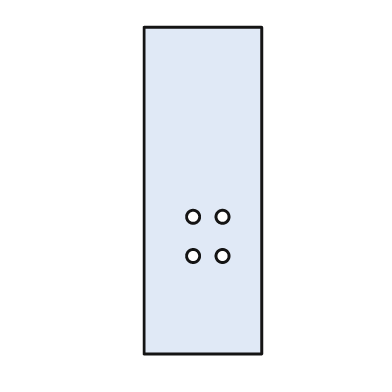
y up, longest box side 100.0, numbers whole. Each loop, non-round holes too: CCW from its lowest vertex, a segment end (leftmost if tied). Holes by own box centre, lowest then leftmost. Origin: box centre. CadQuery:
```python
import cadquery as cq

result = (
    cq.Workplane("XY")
    .moveTo(-18.0, -50.0)
    .lineTo(18.0, -50.0)
    .lineTo(18.0, 50.0)
    .lineTo(-18.0, 50.0)
    .close()
    .moveTo(-3.0, -20.0)
    .circle(2.0)
    .moveTo(6.0, -20.0)
    .circle(2.0)
    .moveTo(-3.0, -8.0)
    .circle(2.0)
    .moveTo(6.0, -8.0)
    .circle(2.0)
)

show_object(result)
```